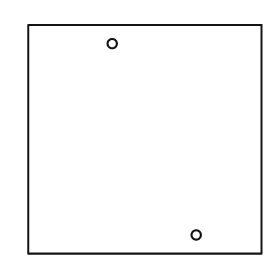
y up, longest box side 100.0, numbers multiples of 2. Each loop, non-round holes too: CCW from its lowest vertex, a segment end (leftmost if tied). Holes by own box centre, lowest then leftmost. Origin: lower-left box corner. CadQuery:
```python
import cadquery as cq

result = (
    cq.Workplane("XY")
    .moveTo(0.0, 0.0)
    .lineTo(100.0, 0.0)
    .lineTo(100.0, 98.0)
    .lineTo(0.0, 98.0)
    .close()
    .moveTo(72.0, 8.0)
    .circle(2.0)
    .moveTo(36.0, 90.0)
    .circle(2.0)
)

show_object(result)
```